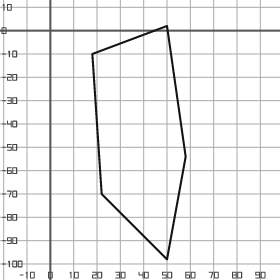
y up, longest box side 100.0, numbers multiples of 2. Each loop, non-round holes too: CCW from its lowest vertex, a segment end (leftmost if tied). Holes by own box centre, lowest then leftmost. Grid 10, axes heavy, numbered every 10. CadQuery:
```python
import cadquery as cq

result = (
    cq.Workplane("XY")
    .moveTo(50.0, -98.0)
    .lineTo(58.0, -54.0)
    .lineTo(50.0, 2.0)
    .lineTo(18.0, -10.0)
    .lineTo(22.0, -70.0)
    .close()
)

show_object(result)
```